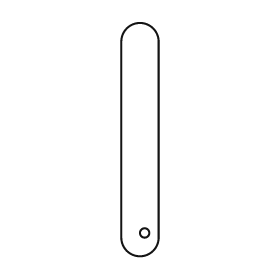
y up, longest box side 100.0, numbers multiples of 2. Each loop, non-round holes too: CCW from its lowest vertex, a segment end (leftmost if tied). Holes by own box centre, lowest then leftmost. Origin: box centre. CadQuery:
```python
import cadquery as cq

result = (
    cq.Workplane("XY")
    .moveTo(-8.0, -42.0)
    .threePointArc((0.0, -50.0), (8.0, -42.0))
    .lineTo(8.0, 42.0)
    .threePointArc((0.0, 50.0), (-8.0, 42.0))
    .close()
    .moveTo(2.0, -40.0)
    .circle(2.0)
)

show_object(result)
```